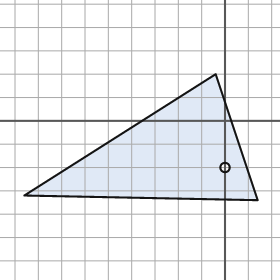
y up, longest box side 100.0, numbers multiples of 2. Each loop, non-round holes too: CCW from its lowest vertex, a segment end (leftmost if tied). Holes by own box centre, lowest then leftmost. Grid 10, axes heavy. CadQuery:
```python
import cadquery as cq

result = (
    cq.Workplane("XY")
    .moveTo(14.0, -34.0)
    .lineTo(-4.0, 20.0)
    .lineTo(-86.0, -32.0)
    .close()
    .moveTo(0.0, -20.0)
    .circle(2.0)
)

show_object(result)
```